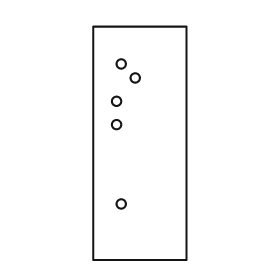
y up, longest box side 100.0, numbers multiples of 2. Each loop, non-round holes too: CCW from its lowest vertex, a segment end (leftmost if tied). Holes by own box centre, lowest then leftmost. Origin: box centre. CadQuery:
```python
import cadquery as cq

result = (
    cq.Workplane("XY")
    .moveTo(-20.0, -50.0)
    .lineTo(20.0, -50.0)
    .lineTo(20.0, 50.0)
    .lineTo(-20.0, 50.0)
    .close()
    .moveTo(-8.0, -26.0)
    .circle(2.0)
    .moveTo(-10.0, 8.0)
    .circle(2.0)
    .moveTo(-10.0, 18.0)
    .circle(2.0)
    .moveTo(-2.0, 28.0)
    .circle(2.0)
    .moveTo(-8.0, 34.0)
    .circle(2.0)
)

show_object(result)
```